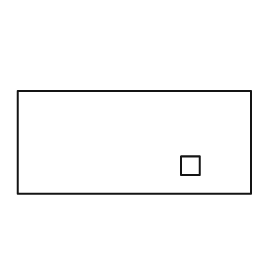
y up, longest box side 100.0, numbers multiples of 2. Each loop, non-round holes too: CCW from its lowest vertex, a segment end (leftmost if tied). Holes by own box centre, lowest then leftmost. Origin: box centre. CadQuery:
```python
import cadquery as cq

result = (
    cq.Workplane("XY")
    .moveTo(-50.0, -22.0)
    .lineTo(50.0, -22.0)
    .lineTo(50.0, 22.0)
    .lineTo(-50.0, 22.0)
    .close()
    .moveTo(20.0, -14.0)
    .lineTo(28.0, -14.0)
    .lineTo(28.0, -6.0)
    .lineTo(20.0, -6.0)
    .close()
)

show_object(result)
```